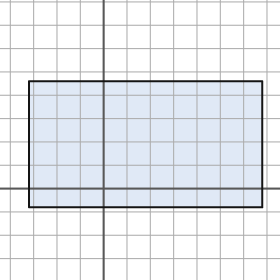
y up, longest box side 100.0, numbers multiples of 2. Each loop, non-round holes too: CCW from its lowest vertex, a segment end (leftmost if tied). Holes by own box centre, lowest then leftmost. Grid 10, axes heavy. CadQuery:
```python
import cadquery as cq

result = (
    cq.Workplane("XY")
    .moveTo(-32.0, -8.0)
    .lineTo(68.0, -8.0)
    .lineTo(68.0, 46.0)
    .lineTo(-32.0, 46.0)
    .close()
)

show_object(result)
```